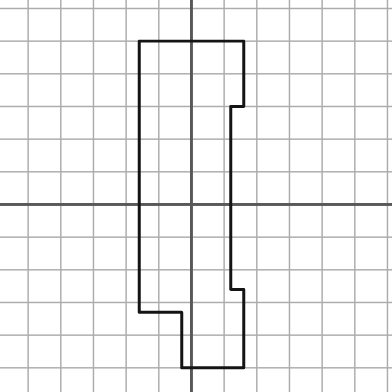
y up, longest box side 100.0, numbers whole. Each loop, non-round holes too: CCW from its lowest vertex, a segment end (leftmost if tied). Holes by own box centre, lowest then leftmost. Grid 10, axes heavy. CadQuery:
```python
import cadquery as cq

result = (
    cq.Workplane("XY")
    .moveTo(-3.0, -50.0)
    .lineTo(16.0, -50.0)
    .lineTo(16.0, -26.0)
    .lineTo(12.0, -26.0)
    .lineTo(12.0, 30.0)
    .lineTo(16.0, 30.0)
    .lineTo(16.0, 50.0)
    .lineTo(-16.0, 50.0)
    .lineTo(-16.0, -33.0)
    .lineTo(-3.0, -33.0)
    .close()
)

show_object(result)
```